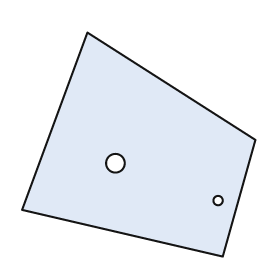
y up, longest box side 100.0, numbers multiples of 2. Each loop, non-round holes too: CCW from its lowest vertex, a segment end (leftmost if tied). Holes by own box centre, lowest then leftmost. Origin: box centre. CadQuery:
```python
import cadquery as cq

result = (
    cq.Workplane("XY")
    .moveTo(36.0, -48.0)
    .lineTo(50.0, 2.0)
    .lineTo(-22.0, 48.0)
    .lineTo(-50.0, -28.0)
    .close()
    .moveTo(34.0, -24.0)
    .circle(2.0)
    .moveTo(-10.0, -8.0)
    .circle(4.0)
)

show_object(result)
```